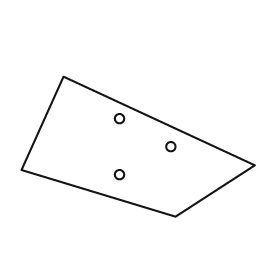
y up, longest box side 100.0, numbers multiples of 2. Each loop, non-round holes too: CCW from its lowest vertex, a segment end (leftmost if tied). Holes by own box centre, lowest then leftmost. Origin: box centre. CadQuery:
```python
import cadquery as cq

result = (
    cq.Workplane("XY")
    .moveTo(16.0, -30.0)
    .lineTo(50.0, -8.0)
    .lineTo(-32.0, 30.0)
    .lineTo(-50.0, -10.0)
    .close()
    .moveTo(-8.0, -12.0)
    .circle(2.0)
    .moveTo(14.0, 0.0)
    .circle(2.0)
    .moveTo(-8.0, 12.0)
    .circle(2.0)
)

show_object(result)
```